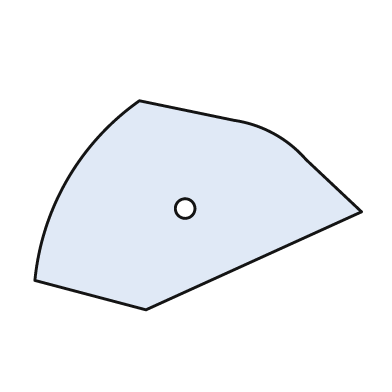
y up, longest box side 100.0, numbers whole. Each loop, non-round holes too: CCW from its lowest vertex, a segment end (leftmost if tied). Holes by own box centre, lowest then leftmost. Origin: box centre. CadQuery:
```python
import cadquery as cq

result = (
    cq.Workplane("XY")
    .moveTo(-16.0, -32.0)
    .lineTo(50.0, -2.0)
    .lineTo(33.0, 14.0)
    .threePointArc((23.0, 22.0), (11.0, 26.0))
    .lineTo(-18.0, 32.0)
    .threePointArc((-40.0, 8.0), (-50.0, -23.0))
    .close()
    .moveTo(-4.0, -1.0)
    .circle(3.0)
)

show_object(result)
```